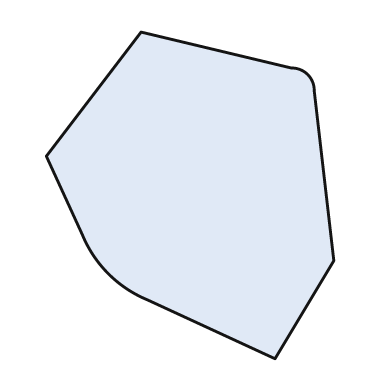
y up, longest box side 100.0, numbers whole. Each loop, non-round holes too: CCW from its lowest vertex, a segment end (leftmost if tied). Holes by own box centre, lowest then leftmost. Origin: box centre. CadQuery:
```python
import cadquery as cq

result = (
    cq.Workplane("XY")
    .moveTo(26.0, -50.0)
    .lineTo(44.0, -20.0)
    .lineTo(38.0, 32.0)
    .threePointArc((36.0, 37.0), (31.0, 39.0))
    .lineTo(-15.0, 50.0)
    .lineTo(-44.0, 12.0)
    .lineTo(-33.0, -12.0)
    .threePointArc((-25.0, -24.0), (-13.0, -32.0))
    .close()
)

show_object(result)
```